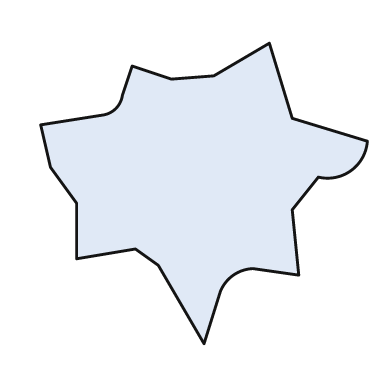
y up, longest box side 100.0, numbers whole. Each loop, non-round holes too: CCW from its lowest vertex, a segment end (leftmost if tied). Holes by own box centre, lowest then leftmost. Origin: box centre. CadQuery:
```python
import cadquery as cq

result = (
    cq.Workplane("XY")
    .moveTo(0.0, -46.0)
    .lineTo(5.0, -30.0)
    .threePointArc((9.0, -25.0), (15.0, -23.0))
    .lineTo(29.0, -25.0)
    .lineTo(27.0, -5.0)
    .lineTo(35.0, 5.0)
    .threePointArc((45.0, 7.0), (50.0, 16.0))
    .lineTo(27.0, 23.0)
    .lineTo(20.0, 46.0)
    .lineTo(3.0, 36.0)
    .lineTo(-10.0, 35.0)
    .lineTo(-22.0, 39.0)
    .lineTo(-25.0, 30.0)
    .threePointArc((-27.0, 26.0), (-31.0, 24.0))
    .lineTo(-50.0, 21.0)
    .lineTo(-47.0, 8.0)
    .lineTo(-39.0, -3.0)
    .lineTo(-39.0, -20.0)
    .lineTo(-21.0, -17.0)
    .lineTo(-14.0, -22.0)
    .close()
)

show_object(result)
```